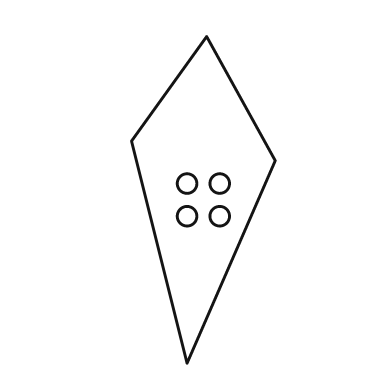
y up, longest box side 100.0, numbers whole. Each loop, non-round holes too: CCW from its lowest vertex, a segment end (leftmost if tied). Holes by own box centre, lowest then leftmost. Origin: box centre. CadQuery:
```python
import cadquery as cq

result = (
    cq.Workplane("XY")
    .moveTo(-5.0, -50.0)
    .lineTo(22.0, 12.0)
    .lineTo(1.0, 50.0)
    .lineTo(-22.0, 18.0)
    .close()
    .moveTo(-5.0, -5.0)
    .circle(3.0)
    .moveTo(5.0, -5.0)
    .circle(3.0)
    .moveTo(-5.0, 5.0)
    .circle(3.0)
    .moveTo(5.0, 5.0)
    .circle(3.0)
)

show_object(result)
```